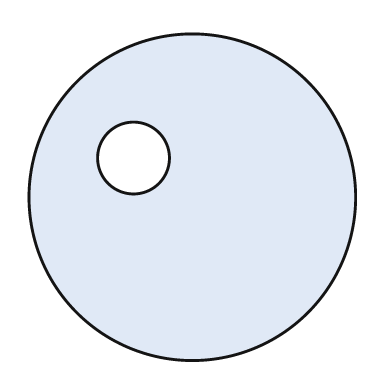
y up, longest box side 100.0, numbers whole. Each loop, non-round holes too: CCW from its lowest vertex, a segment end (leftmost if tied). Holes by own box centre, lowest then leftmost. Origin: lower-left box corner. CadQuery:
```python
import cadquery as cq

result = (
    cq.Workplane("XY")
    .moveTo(50.0, 50.0)
    .circle(50.0)
    .moveTo(32.0, 62.0)
    .circle(11.0)
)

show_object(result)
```